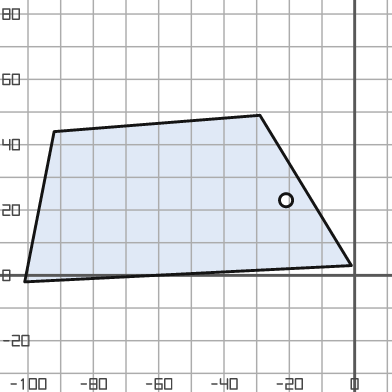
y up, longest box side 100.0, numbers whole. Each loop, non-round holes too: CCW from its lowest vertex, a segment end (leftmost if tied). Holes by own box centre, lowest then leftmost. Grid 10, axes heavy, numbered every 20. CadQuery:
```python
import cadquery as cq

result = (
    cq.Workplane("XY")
    .moveTo(-101.0, -2.0)
    .lineTo(-1.0, 3.0)
    .lineTo(-29.0, 49.0)
    .lineTo(-92.0, 44.0)
    .close()
    .moveTo(-21.0, 23.0)
    .circle(2.0)
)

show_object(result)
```